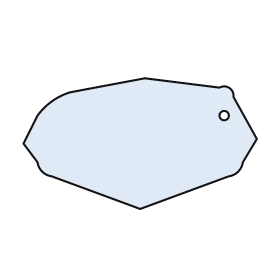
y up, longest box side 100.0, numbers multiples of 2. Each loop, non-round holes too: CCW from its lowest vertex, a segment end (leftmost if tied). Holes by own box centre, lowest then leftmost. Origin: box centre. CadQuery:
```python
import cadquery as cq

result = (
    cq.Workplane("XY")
    .moveTo(0.0, -28.0)
    .lineTo(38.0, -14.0)
    .threePointArc((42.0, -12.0), (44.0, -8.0))
    .lineTo(50.0, 2.0)
    .lineTo(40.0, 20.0)
    .threePointArc((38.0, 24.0), (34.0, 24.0))
    .lineTo(2.0, 28.0)
    .lineTo(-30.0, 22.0)
    .threePointArc((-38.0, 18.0), (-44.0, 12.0))
    .lineTo(-50.0, 0.0)
    .lineTo(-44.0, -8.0)
    .threePointArc((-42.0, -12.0), (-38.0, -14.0))
    .close()
    .moveTo(36.0, 12.0)
    .circle(2.0)
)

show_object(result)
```